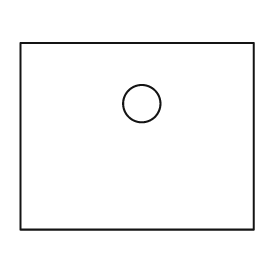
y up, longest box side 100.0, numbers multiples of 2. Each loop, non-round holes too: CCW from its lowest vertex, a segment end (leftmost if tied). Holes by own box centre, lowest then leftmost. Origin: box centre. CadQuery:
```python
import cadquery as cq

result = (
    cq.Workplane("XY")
    .moveTo(-50.0, -40.0)
    .lineTo(50.0, -40.0)
    .lineTo(50.0, 40.0)
    .lineTo(-50.0, 40.0)
    .close()
    .moveTo(2.0, 14.0)
    .circle(8.0)
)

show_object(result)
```